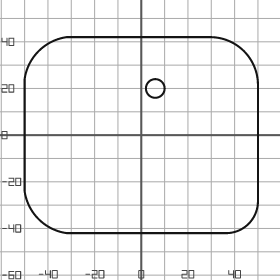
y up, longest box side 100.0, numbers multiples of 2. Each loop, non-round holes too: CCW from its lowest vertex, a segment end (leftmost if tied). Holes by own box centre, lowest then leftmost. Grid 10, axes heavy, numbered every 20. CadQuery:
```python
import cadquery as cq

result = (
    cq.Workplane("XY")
    .moveTo(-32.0, -42.0)
    .lineTo(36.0, -42.0)
    .threePointArc((46.0, -38.0), (50.0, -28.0))
    .lineTo(50.0, 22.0)
    .threePointArc((44.0, 36.0), (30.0, 42.0))
    .lineTo(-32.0, 42.0)
    .threePointArc((-44.0, 36.0), (-50.0, 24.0))
    .lineTo(-50.0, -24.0)
    .threePointArc((-44.0, -36.0), (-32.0, -42.0))
    .close()
    .moveTo(6.0, 20.0)
    .circle(4.0)
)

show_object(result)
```